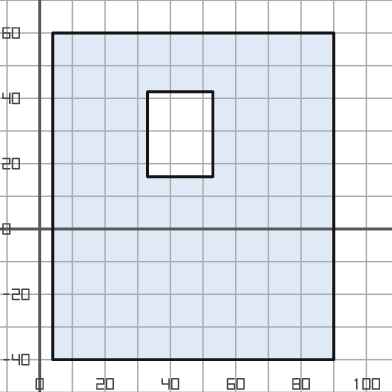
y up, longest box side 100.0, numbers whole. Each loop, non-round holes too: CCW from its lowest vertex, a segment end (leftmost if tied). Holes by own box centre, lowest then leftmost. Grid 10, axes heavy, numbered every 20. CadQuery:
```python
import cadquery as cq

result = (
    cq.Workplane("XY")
    .moveTo(4.0, -40.0)
    .lineTo(90.0, -40.0)
    .lineTo(90.0, 60.0)
    .lineTo(4.0, 60.0)
    .close()
    .moveTo(33.0, 16.0)
    .lineTo(53.0, 16.0)
    .lineTo(53.0, 42.0)
    .lineTo(33.0, 42.0)
    .close()
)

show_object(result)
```